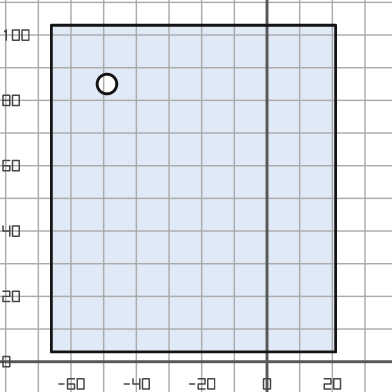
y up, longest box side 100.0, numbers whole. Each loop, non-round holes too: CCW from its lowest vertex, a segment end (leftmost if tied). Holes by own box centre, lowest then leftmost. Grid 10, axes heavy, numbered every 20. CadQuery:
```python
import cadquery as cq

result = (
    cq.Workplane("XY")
    .moveTo(-66.0, 3.0)
    .lineTo(21.0, 3.0)
    .lineTo(21.0, 103.0)
    .lineTo(-66.0, 103.0)
    .close()
    .moveTo(-49.0, 85.0)
    .circle(3.0)
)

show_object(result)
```